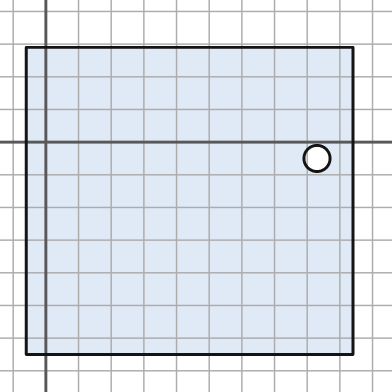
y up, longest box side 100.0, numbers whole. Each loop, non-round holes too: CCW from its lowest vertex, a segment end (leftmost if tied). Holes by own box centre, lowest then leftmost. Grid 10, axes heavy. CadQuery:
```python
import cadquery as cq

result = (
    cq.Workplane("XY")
    .moveTo(-6.0, -65.0)
    .lineTo(94.0, -65.0)
    .lineTo(94.0, 29.0)
    .lineTo(-6.0, 29.0)
    .close()
    .moveTo(83.0, -5.0)
    .circle(4.0)
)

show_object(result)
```